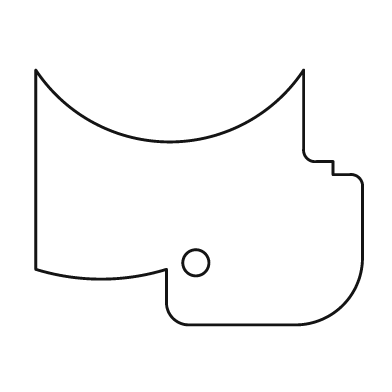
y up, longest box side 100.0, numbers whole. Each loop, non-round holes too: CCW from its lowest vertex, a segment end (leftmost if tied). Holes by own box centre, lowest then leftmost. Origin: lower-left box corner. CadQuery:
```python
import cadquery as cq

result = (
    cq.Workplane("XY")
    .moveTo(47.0, 0.0)
    .lineTo(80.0, 0.0)
    .threePointArc((94.0, 6.0), (100.0, 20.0))
    .lineTo(100.0, 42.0)
    .threePointArc((99.0, 45.0), (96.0, 46.0))
    .lineTo(91.0, 46.0)
    .lineTo(91.0, 50.0)
    .lineTo(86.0, 50.0)
    .threePointArc((83.0, 51.0), (82.0, 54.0))
    .lineTo(82.0, 78.0)
    .threePointArc((41.0, 56.0), (0.0, 78.0))
    .lineTo(0.0, 17.0)
    .threePointArc((20.0, 14.0), (40.0, 17.0))
    .lineTo(40.0, 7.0)
    .threePointArc((42.0, 2.0), (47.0, 0.0))
    .close()
    .moveTo(49.0, 19.0)
    .circle(4.0)
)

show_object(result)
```